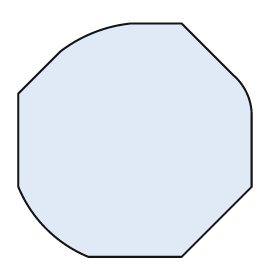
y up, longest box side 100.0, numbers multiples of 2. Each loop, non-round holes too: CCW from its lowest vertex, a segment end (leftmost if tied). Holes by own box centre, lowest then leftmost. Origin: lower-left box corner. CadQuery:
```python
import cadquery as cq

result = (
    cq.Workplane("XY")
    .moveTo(30.0, 0.0)
    .lineTo(70.0, 0.0)
    .lineTo(100.0, 30.0)
    .lineTo(100.0, 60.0)
    .threePointArc((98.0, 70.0), (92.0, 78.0))
    .lineTo(70.0, 100.0)
    .lineTo(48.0, 100.0)
    .threePointArc((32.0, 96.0), (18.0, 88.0))
    .lineTo(0.0, 70.0)
    .lineTo(0.0, 30.0)
    .threePointArc((12.0, 12.0), (30.0, 0.0))
    .close()
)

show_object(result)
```